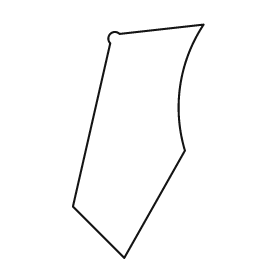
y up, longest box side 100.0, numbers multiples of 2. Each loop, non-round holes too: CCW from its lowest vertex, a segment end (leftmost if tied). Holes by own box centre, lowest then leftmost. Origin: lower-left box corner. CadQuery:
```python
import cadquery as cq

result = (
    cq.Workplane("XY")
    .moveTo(22.0, 0.0)
    .lineTo(48.0, 46.0)
    .threePointArc((46.0, 74.0), (56.0, 100.0))
    .lineTo(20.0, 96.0)
    .threePointArc((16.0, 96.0), (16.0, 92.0))
    .lineTo(0.0, 22.0)
    .close()
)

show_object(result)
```